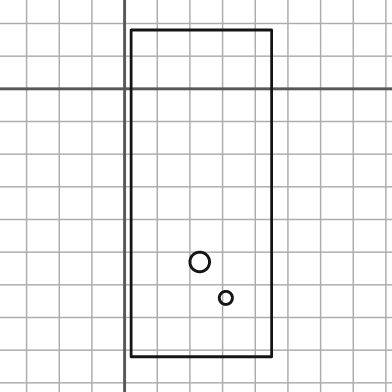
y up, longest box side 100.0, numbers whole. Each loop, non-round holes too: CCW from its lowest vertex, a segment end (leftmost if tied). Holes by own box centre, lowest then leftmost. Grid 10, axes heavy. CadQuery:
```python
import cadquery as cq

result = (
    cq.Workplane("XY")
    .moveTo(2.0, -82.0)
    .lineTo(45.0, -82.0)
    .lineTo(45.0, 18.0)
    .lineTo(2.0, 18.0)
    .close()
    .moveTo(31.0, -64.0)
    .circle(2.0)
    .moveTo(23.0, -53.0)
    .circle(3.0)
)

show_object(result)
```